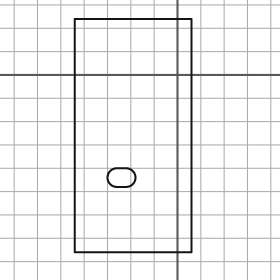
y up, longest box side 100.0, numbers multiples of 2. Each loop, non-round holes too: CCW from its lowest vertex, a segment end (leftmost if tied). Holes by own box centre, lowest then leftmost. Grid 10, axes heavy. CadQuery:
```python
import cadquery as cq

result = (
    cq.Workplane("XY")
    .moveTo(-44.0, -76.0)
    .lineTo(6.0, -76.0)
    .lineTo(6.0, 24.0)
    .lineTo(-44.0, 24.0)
    .close()
    .moveTo(-26.0, -48.0)
    .lineTo(-22.0, -48.0)
    .threePointArc((-18.0, -44.0), (-22.0, -40.0))
    .lineTo(-26.0, -40.0)
    .threePointArc((-30.0, -44.0), (-26.0, -48.0))
    .close()
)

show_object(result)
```